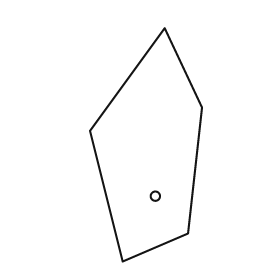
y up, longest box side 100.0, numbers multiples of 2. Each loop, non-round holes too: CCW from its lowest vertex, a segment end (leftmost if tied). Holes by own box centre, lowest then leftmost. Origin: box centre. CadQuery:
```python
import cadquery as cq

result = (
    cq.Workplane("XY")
    .moveTo(-10.0, -50.0)
    .lineTo(18.0, -38.0)
    .lineTo(24.0, 16.0)
    .lineTo(8.0, 50.0)
    .lineTo(-24.0, 6.0)
    .close()
    .moveTo(4.0, -22.0)
    .circle(2.0)
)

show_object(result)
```